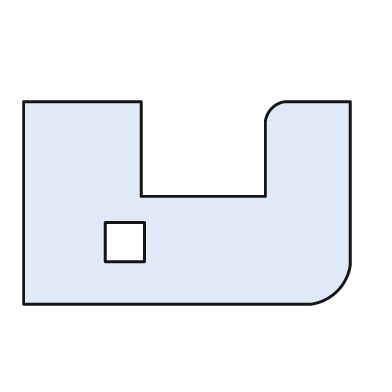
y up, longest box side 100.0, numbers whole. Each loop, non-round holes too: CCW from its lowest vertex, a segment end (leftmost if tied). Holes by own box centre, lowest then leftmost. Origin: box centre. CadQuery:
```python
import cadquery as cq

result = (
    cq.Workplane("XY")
    .moveTo(-50.0, -31.0)
    .lineTo(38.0, -31.0)
    .threePointArc((46.0, -27.0), (50.0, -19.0))
    .lineTo(50.0, 31.0)
    .lineTo(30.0, 31.0)
    .threePointArc((26.0, 29.0), (24.0, 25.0))
    .lineTo(24.0, 2.0)
    .lineTo(-14.0, 2.0)
    .lineTo(-14.0, 31.0)
    .lineTo(-50.0, 31.0)
    .close()
    .moveTo(-25.0, -18.0)
    .lineTo(-13.0, -18.0)
    .lineTo(-13.0, -6.0)
    .lineTo(-25.0, -6.0)
    .close()
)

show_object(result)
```